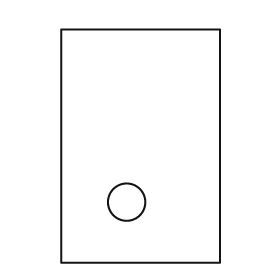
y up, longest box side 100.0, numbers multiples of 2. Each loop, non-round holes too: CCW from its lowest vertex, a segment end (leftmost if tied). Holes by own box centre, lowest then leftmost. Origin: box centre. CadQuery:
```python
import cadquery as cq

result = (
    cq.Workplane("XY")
    .moveTo(-34.0, -50.0)
    .lineTo(34.0, -50.0)
    .lineTo(34.0, 50.0)
    .lineTo(-34.0, 50.0)
    .close()
    .moveTo(-6.0, -24.0)
    .circle(8.0)
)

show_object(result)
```